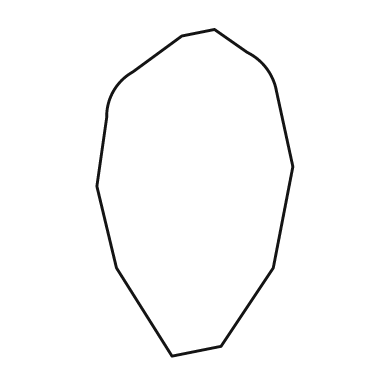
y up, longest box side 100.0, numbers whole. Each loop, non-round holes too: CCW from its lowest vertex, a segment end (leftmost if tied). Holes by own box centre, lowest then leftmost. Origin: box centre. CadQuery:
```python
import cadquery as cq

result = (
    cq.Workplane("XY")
    .moveTo(-7.0, -50.0)
    .lineTo(8.0, -47.0)
    .lineTo(24.0, -23.0)
    .lineTo(30.0, 8.0)
    .lineTo(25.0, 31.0)
    .threePointArc((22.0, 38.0), (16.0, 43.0))
    .lineTo(6.0, 50.0)
    .lineTo(-4.0, 48.0)
    .lineTo(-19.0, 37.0)
    .threePointArc((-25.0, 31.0), (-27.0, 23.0))
    .lineTo(-30.0, 2.0)
    .lineTo(-24.0, -23.0)
    .close()
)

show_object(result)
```